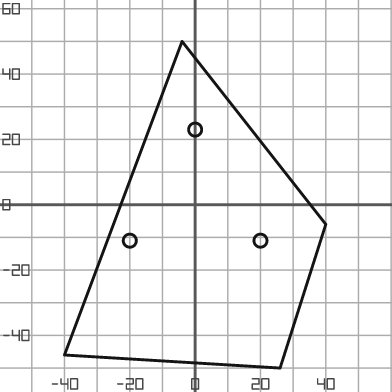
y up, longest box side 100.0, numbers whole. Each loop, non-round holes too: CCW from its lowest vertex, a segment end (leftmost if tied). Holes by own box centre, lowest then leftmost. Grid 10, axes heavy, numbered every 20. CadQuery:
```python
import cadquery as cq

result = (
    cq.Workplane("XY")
    .moveTo(26.0, -50.0)
    .lineTo(40.0, -6.0)
    .lineTo(-4.0, 50.0)
    .lineTo(-40.0, -46.0)
    .close()
    .moveTo(-20.0, -11.0)
    .circle(2.0)
    .moveTo(20.0, -11.0)
    .circle(2.0)
    .moveTo(0.0, 23.0)
    .circle(2.0)
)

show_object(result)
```